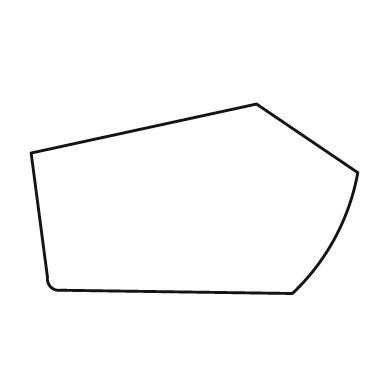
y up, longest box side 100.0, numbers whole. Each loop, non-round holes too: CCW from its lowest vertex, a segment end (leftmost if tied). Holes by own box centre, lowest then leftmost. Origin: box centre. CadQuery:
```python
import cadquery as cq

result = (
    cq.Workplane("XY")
    .moveTo(30.0, -29.0)
    .threePointArc((43.0, -12.0), (50.0, 8.0))
    .lineTo(19.0, 29.0)
    .lineTo(-50.0, 14.0)
    .lineTo(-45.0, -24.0)
    .threePointArc((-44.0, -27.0), (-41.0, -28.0))
    .close()
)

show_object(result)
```